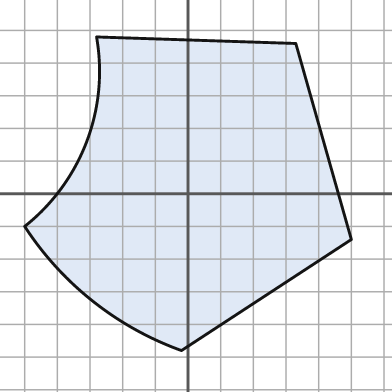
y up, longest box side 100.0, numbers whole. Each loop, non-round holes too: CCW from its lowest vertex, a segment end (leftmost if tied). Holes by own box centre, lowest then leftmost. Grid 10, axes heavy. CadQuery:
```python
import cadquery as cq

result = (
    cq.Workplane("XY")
    .moveTo(-2.0, -48.0)
    .lineTo(50.0, -14.0)
    .lineTo(33.0, 46.0)
    .lineTo(-28.0, 48.0)
    .threePointArc((-31.0, 16.0), (-50.0, -10.0))
    .threePointArc((-29.0, -33.0), (-2.0, -48.0))
    .close()
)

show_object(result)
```